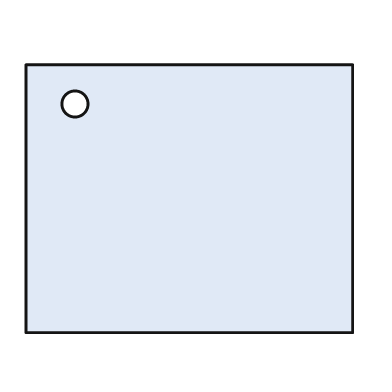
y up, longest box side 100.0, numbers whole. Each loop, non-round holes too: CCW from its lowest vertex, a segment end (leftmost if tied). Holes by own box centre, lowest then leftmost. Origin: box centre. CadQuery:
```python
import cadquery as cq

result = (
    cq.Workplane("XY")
    .moveTo(-50.0, -41.0)
    .lineTo(50.0, -41.0)
    .lineTo(50.0, 41.0)
    .lineTo(-50.0, 41.0)
    .close()
    .moveTo(-35.0, 29.0)
    .circle(4.0)
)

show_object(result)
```